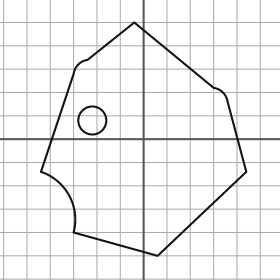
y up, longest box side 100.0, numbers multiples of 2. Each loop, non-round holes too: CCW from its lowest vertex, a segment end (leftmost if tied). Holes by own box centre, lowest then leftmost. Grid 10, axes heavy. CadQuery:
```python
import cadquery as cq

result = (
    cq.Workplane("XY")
    .moveTo(6.0, -50.0)
    .lineTo(44.0, -14.0)
    .lineTo(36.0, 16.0)
    .threePointArc((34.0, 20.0), (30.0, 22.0))
    .lineTo(-4.0, 50.0)
    .lineTo(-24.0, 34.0)
    .threePointArc((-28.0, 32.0), (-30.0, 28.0))
    .lineTo(-44.0, -14.0)
    .threePointArc((-32.0, -24.0), (-30.0, -40.0))
    .close()
    .moveTo(-22.0, 8.0)
    .circle(6.0)
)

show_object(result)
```